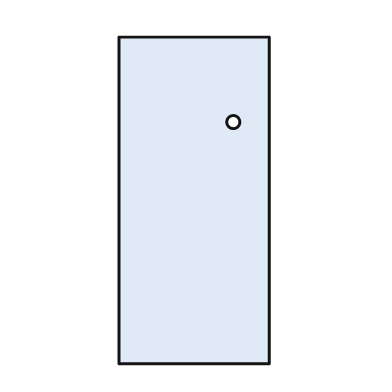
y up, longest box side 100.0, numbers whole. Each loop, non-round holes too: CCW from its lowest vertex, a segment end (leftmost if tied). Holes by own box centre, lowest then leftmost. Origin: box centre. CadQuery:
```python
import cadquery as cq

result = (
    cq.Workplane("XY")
    .moveTo(-23.0, -50.0)
    .lineTo(23.0, -50.0)
    .lineTo(23.0, 50.0)
    .lineTo(-23.0, 50.0)
    .close()
    .moveTo(12.0, 24.0)
    .circle(2.0)
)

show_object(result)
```